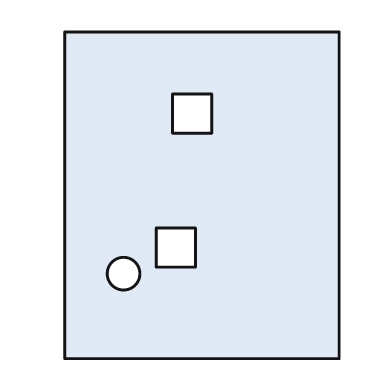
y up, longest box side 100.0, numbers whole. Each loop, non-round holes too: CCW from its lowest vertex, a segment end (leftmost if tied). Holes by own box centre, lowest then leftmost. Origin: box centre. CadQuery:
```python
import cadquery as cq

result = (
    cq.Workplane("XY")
    .moveTo(-42.0, -50.0)
    .lineTo(42.0, -50.0)
    .lineTo(42.0, 50.0)
    .lineTo(-42.0, 50.0)
    .close()
    .moveTo(-24.0, -24.0)
    .circle(5.0)
    .moveTo(-14.0, -22.0)
    .lineTo(-2.0, -22.0)
    .lineTo(-2.0, -10.0)
    .lineTo(-14.0, -10.0)
    .close()
    .moveTo(-9.0, 19.0)
    .lineTo(3.0, 19.0)
    .lineTo(3.0, 31.0)
    .lineTo(-9.0, 31.0)
    .close()
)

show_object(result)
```